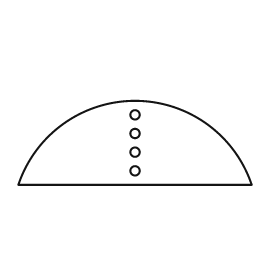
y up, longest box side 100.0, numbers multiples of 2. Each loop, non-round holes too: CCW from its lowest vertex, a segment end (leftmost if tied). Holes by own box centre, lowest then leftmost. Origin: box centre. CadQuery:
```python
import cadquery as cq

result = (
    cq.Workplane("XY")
    .moveTo(-50.0, -18.0)
    .lineTo(50.0, -18.0)
    .threePointArc((0.0, 18.0), (-50.0, -18.0))
    .close()
    .moveTo(0.0, -12.0)
    .circle(2.0)
    .moveTo(0.0, -4.0)
    .circle(2.0)
    .moveTo(0.0, 4.0)
    .circle(2.0)
    .moveTo(0.0, 12.0)
    .circle(2.0)
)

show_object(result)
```